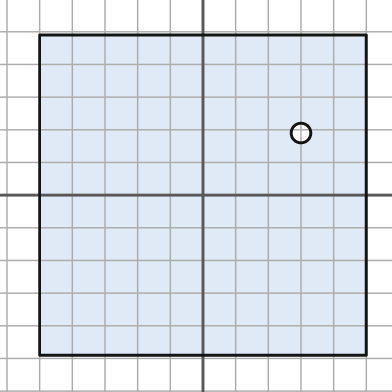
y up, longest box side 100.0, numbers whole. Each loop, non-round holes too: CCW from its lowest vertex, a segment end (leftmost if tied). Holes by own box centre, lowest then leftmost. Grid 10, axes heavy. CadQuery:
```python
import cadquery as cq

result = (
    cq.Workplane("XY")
    .moveTo(-50.0, -49.0)
    .lineTo(50.0, -49.0)
    .lineTo(50.0, 49.0)
    .lineTo(-50.0, 49.0)
    .close()
    .moveTo(30.0, 19.0)
    .circle(3.0)
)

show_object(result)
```